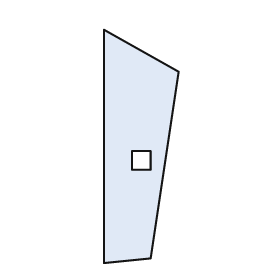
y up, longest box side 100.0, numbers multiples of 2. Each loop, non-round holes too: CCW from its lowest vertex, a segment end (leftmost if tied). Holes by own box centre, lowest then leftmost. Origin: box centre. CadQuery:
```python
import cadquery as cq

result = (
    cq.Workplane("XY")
    .moveTo(-16.0, -50.0)
    .lineTo(4.0, -48.0)
    .lineTo(16.0, 32.0)
    .lineTo(-16.0, 50.0)
    .close()
    .moveTo(-4.0, -10.0)
    .lineTo(4.0, -10.0)
    .lineTo(4.0, -2.0)
    .lineTo(-4.0, -2.0)
    .close()
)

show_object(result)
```